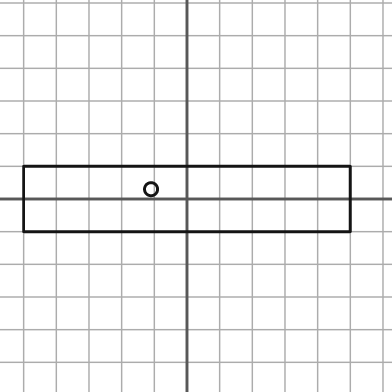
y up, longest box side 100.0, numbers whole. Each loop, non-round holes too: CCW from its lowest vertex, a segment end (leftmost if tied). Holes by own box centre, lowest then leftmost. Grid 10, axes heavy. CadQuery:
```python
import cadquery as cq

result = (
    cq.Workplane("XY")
    .moveTo(-50.0, -10.0)
    .lineTo(50.0, -10.0)
    .lineTo(50.0, 10.0)
    .lineTo(-50.0, 10.0)
    .close()
    .moveTo(-11.0, 3.0)
    .circle(2.0)
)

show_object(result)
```